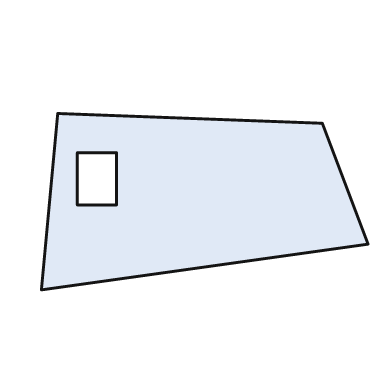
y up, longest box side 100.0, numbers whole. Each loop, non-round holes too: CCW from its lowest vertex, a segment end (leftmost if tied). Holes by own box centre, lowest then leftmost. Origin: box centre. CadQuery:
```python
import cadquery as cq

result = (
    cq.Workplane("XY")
    .moveTo(-50.0, -27.0)
    .lineTo(50.0, -13.0)
    .lineTo(36.0, 24.0)
    .lineTo(-45.0, 27.0)
    .close()
    .moveTo(-39.0, -1.0)
    .lineTo(-27.0, -1.0)
    .lineTo(-27.0, 15.0)
    .lineTo(-39.0, 15.0)
    .close()
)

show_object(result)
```